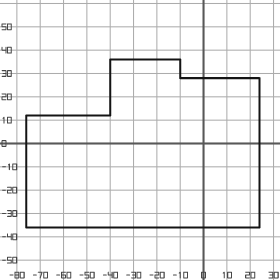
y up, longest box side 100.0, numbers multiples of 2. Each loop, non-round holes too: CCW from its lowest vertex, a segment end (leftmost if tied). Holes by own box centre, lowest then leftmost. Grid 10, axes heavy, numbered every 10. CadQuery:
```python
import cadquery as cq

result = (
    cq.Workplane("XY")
    .moveTo(-76.0, -36.0)
    .lineTo(24.0, -36.0)
    .lineTo(24.0, 28.0)
    .lineTo(-10.0, 28.0)
    .lineTo(-10.0, 36.0)
    .lineTo(-40.0, 36.0)
    .lineTo(-40.0, 12.0)
    .lineTo(-76.0, 12.0)
    .close()
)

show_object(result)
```